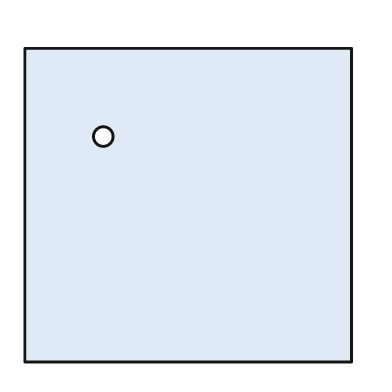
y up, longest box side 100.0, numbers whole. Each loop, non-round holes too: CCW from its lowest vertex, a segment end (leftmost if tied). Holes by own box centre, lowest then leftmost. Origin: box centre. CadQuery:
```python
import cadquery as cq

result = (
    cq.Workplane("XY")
    .moveTo(-50.0, -48.0)
    .lineTo(50.0, -48.0)
    .lineTo(50.0, 48.0)
    .lineTo(-50.0, 48.0)
    .close()
    .moveTo(-26.0, 21.0)
    .circle(3.0)
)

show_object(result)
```